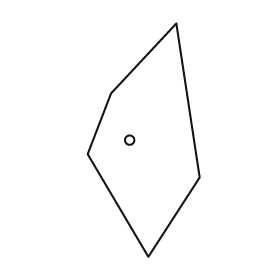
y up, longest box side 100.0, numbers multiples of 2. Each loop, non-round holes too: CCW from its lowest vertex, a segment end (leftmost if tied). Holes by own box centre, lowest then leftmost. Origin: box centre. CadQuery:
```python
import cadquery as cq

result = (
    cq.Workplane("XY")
    .moveTo(2.0, -50.0)
    .lineTo(24.0, -16.0)
    .lineTo(14.0, 50.0)
    .lineTo(-14.0, 20.0)
    .lineTo(-24.0, -6.0)
    .close()
    .moveTo(-6.0, 0.0)
    .circle(2.0)
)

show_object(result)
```